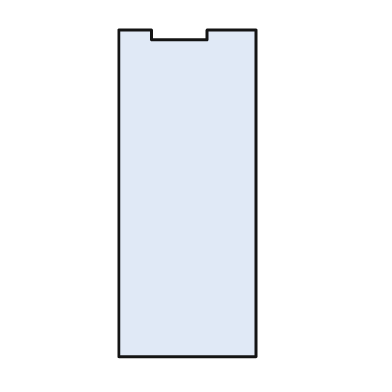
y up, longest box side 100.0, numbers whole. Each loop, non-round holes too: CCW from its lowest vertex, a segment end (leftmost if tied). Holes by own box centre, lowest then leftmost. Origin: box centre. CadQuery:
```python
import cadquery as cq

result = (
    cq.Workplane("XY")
    .moveTo(-21.0, -50.0)
    .lineTo(21.0, -50.0)
    .lineTo(21.0, 50.0)
    .lineTo(6.0, 50.0)
    .lineTo(6.0, 47.0)
    .lineTo(-11.0, 47.0)
    .lineTo(-11.0, 50.0)
    .lineTo(-21.0, 50.0)
    .close()
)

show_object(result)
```